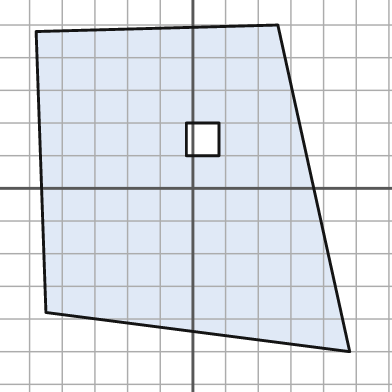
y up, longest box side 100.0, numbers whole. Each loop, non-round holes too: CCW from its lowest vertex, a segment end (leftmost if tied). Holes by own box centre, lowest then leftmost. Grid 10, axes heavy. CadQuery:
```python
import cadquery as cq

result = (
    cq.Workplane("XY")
    .moveTo(48.0, -50.0)
    .lineTo(26.0, 50.0)
    .lineTo(-48.0, 48.0)
    .lineTo(-45.0, -38.0)
    .close()
    .moveTo(-2.0, 10.0)
    .lineTo(8.0, 10.0)
    .lineTo(8.0, 20.0)
    .lineTo(-2.0, 20.0)
    .close()
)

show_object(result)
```